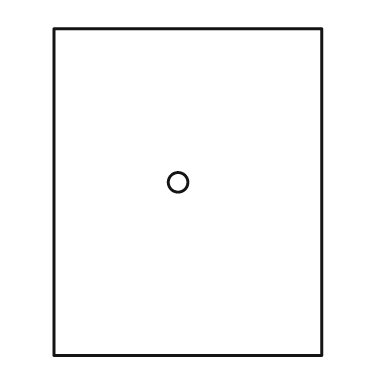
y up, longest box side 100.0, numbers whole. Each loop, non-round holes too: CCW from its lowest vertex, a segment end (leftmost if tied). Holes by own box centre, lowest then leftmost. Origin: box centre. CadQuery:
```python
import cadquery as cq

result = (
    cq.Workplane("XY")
    .moveTo(-41.0, -50.0)
    .lineTo(41.0, -50.0)
    .lineTo(41.0, 50.0)
    .lineTo(-41.0, 50.0)
    .close()
    .moveTo(-3.0, 3.0)
    .circle(3.0)
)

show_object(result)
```